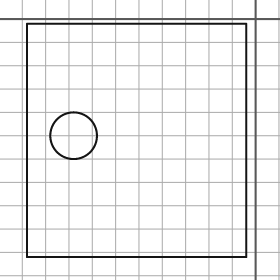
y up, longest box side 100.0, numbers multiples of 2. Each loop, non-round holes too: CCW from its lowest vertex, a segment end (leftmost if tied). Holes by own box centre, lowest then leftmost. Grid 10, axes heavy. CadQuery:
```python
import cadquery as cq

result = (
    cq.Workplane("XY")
    .moveTo(-98.0, -102.0)
    .lineTo(-4.0, -102.0)
    .lineTo(-4.0, -2.0)
    .lineTo(-98.0, -2.0)
    .close()
    .moveTo(-78.0, -50.0)
    .circle(10.0)
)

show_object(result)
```